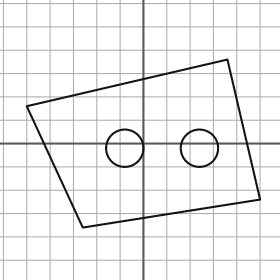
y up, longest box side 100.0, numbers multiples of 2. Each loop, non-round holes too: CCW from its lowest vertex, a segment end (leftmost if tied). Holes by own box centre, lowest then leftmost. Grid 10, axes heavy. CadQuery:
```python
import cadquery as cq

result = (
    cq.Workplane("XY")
    .moveTo(-26.0, -36.0)
    .lineTo(50.0, -24.0)
    .lineTo(36.0, 36.0)
    .lineTo(-50.0, 16.0)
    .close()
    .moveTo(-8.0, -2.0)
    .circle(8.0)
    .moveTo(24.0, -2.0)
    .circle(8.0)
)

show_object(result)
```